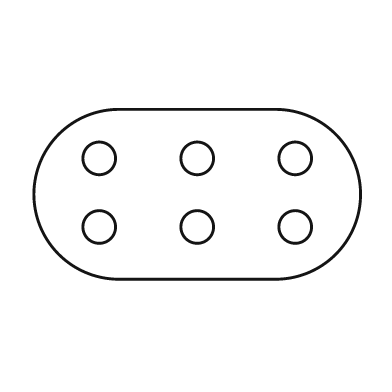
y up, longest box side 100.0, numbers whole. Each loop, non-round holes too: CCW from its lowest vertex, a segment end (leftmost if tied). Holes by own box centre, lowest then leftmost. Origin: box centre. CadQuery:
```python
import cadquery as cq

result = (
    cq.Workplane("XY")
    .moveTo(-24.0, -26.0)
    .lineTo(24.0, -26.0)
    .threePointArc((50.0, 0.0), (24.0, 26.0))
    .lineTo(-24.0, 26.0)
    .threePointArc((-50.0, 0.0), (-24.0, -26.0))
    .close()
    .moveTo(-30.0, -10.0)
    .circle(5.0)
    .moveTo(0.0, -10.0)
    .circle(5.0)
    .moveTo(30.0, -10.0)
    .circle(5.0)
    .moveTo(-30.0, 11.0)
    .circle(5.0)
    .moveTo(0.0, 11.0)
    .circle(5.0)
    .moveTo(30.0, 11.0)
    .circle(5.0)
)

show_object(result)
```